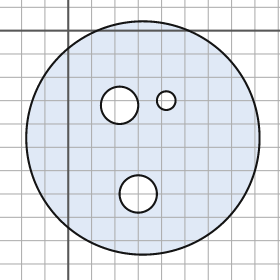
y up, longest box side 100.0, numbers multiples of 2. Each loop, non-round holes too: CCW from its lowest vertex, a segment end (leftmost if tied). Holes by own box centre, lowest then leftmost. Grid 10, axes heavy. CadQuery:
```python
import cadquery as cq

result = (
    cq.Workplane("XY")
    .moveTo(32.0, -46.0)
    .circle(50.0)
    .moveTo(30.0, -70.0)
    .circle(8.0)
    .moveTo(22.0, -32.0)
    .circle(8.0)
    .moveTo(42.0, -30.0)
    .circle(4.0)
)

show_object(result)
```